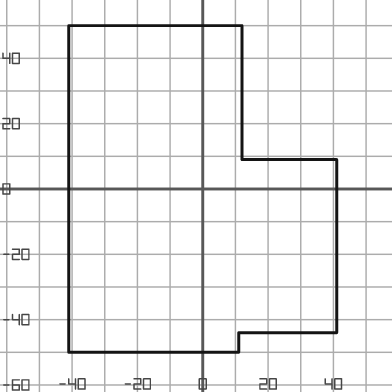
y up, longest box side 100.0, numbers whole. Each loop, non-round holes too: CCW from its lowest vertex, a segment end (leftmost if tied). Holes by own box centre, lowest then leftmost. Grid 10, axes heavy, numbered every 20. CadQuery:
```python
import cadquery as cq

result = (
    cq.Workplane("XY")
    .moveTo(-41.0, -50.0)
    .lineTo(11.0, -50.0)
    .lineTo(11.0, -44.0)
    .lineTo(41.0, -44.0)
    .lineTo(41.0, 9.0)
    .lineTo(12.0, 9.0)
    .lineTo(12.0, 50.0)
    .lineTo(-41.0, 50.0)
    .close()
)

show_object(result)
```